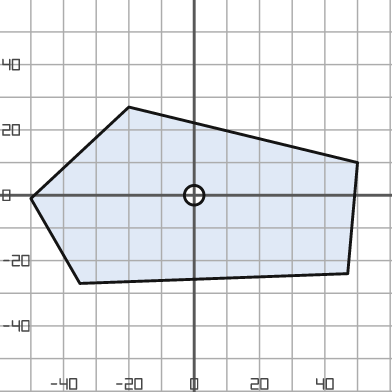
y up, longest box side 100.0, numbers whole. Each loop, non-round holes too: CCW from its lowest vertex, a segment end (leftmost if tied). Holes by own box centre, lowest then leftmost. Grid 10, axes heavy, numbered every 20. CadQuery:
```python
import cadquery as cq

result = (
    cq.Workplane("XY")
    .moveTo(-35.0, -27.0)
    .lineTo(47.0, -24.0)
    .lineTo(50.0, 10.0)
    .lineTo(-20.0, 27.0)
    .lineTo(-50.0, -1.0)
    .close()
    .moveTo(0.0, 0.0)
    .circle(3.0)
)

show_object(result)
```